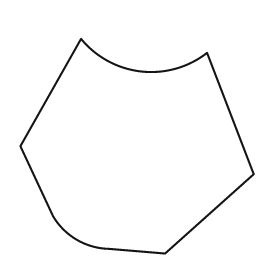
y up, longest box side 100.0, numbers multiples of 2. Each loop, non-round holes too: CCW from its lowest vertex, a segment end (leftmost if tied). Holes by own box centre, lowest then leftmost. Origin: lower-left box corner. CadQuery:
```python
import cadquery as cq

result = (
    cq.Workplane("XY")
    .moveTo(62.0, 0.0)
    .lineTo(100.0, 34.0)
    .lineTo(80.0, 86.0)
    .threePointArc((52.0, 78.0), (26.0, 92.0))
    .lineTo(0.0, 46.0)
    .lineTo(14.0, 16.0)
    .threePointArc((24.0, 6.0), (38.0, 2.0))
    .close()
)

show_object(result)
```